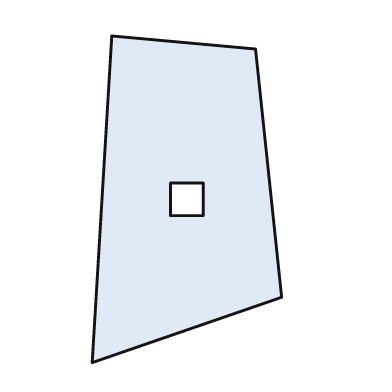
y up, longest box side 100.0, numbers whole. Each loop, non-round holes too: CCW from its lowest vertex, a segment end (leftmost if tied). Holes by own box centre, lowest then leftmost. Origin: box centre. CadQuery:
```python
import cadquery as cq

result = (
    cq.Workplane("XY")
    .moveTo(-29.0, -50.0)
    .lineTo(29.0, -30.0)
    .lineTo(21.0, 46.0)
    .lineTo(-23.0, 50.0)
    .close()
    .moveTo(-5.0, -5.0)
    .lineTo(5.0, -5.0)
    .lineTo(5.0, 5.0)
    .lineTo(-5.0, 5.0)
    .close()
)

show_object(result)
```